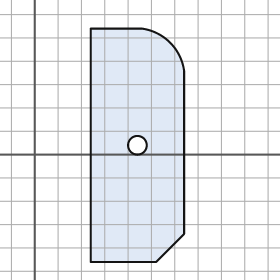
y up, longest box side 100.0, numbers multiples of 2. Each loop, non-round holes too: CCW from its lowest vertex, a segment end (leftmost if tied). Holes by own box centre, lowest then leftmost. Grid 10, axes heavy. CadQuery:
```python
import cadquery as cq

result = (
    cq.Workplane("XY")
    .moveTo(24.0, -46.0)
    .lineTo(52.0, -46.0)
    .lineTo(64.0, -34.0)
    .lineTo(64.0, 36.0)
    .threePointArc((58.0, 48.0), (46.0, 54.0))
    .lineTo(24.0, 54.0)
    .close()
    .moveTo(44.0, 4.0)
    .circle(4.0)
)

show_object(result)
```